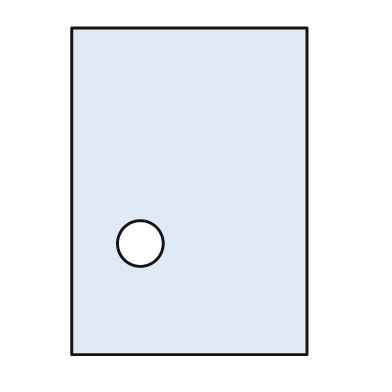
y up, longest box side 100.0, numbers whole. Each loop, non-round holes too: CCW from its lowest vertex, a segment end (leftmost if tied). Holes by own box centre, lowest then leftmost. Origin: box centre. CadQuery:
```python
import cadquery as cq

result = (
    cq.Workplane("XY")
    .moveTo(-36.0, -50.0)
    .lineTo(36.0, -50.0)
    .lineTo(36.0, 50.0)
    .lineTo(-36.0, 50.0)
    .close()
    .moveTo(-15.0, -16.0)
    .circle(7.0)
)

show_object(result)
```